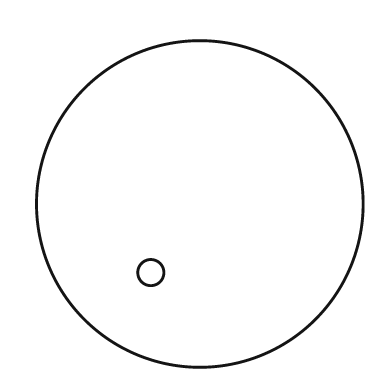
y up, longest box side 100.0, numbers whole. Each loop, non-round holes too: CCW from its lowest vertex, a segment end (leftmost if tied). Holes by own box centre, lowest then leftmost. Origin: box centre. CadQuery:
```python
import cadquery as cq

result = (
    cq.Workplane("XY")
    .moveTo(0.0, 0.0)
    .circle(50.0)
    .moveTo(-15.0, -21.0)
    .circle(4.0)
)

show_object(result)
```